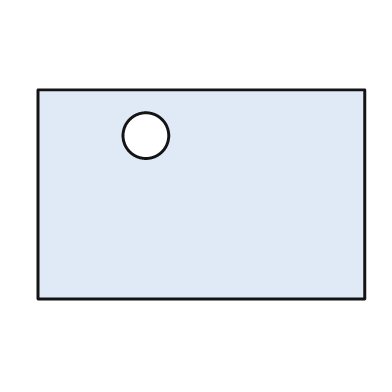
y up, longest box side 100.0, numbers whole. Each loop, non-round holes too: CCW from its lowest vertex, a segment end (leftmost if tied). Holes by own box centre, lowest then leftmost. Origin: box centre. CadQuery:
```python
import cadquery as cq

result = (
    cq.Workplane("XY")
    .moveTo(-50.0, -32.0)
    .lineTo(50.0, -32.0)
    .lineTo(50.0, 32.0)
    .lineTo(-50.0, 32.0)
    .close()
    .moveTo(-17.0, 18.0)
    .circle(7.0)
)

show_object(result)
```